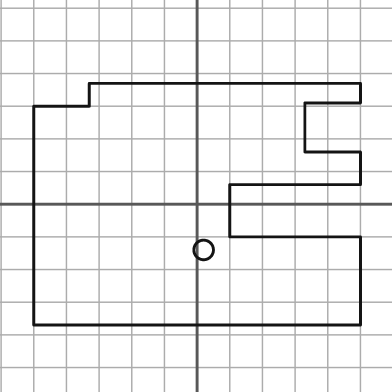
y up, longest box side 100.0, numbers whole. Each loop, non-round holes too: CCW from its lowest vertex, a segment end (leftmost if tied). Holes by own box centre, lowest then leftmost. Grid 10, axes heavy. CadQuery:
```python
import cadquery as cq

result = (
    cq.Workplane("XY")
    .moveTo(-50.0, -37.0)
    .lineTo(50.0, -37.0)
    .lineTo(50.0, -10.0)
    .lineTo(10.0, -10.0)
    .lineTo(10.0, 6.0)
    .lineTo(50.0, 6.0)
    .lineTo(50.0, 16.0)
    .lineTo(33.0, 16.0)
    .lineTo(33.0, 31.0)
    .lineTo(50.0, 31.0)
    .lineTo(50.0, 37.0)
    .lineTo(-33.0, 37.0)
    .lineTo(-33.0, 30.0)
    .lineTo(-50.0, 30.0)
    .close()
    .moveTo(2.0, -14.0)
    .circle(3.0)
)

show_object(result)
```